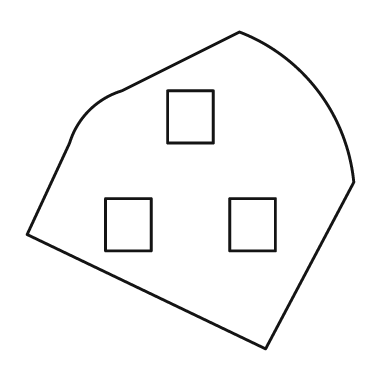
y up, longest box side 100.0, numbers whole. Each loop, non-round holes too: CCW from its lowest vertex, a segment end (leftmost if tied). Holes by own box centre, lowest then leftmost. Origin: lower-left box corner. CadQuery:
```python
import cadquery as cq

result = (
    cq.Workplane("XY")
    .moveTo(73.0, 0.0)
    .lineTo(100.0, 51.0)
    .threePointArc((89.0, 79.0), (65.0, 97.0))
    .lineTo(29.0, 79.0)
    .threePointArc((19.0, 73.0), (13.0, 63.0))
    .lineTo(0.0, 35.0)
    .close()
    .moveTo(24.0, 30.0)
    .lineTo(38.0, 30.0)
    .lineTo(38.0, 46.0)
    .lineTo(24.0, 46.0)
    .close()
    .moveTo(62.0, 30.0)
    .lineTo(76.0, 30.0)
    .lineTo(76.0, 46.0)
    .lineTo(62.0, 46.0)
    .close()
    .moveTo(43.0, 63.0)
    .lineTo(57.0, 63.0)
    .lineTo(57.0, 79.0)
    .lineTo(43.0, 79.0)
    .close()
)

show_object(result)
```